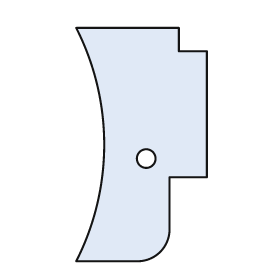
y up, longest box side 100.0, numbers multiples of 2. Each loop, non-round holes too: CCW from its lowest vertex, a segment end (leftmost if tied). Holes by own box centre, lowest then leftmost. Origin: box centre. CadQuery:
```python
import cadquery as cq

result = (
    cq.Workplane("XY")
    .moveTo(-28.0, -50.0)
    .lineTo(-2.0, -50.0)
    .threePointArc((8.0, -46.0), (12.0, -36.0))
    .lineTo(12.0, -14.0)
    .lineTo(28.0, -14.0)
    .lineTo(28.0, 40.0)
    .lineTo(16.0, 40.0)
    .lineTo(16.0, 50.0)
    .lineTo(-28.0, 50.0)
    .threePointArc((-16.0, 0.0), (-28.0, -50.0))
    .close()
    .moveTo(2.0, -6.0)
    .circle(4.0)
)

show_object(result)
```